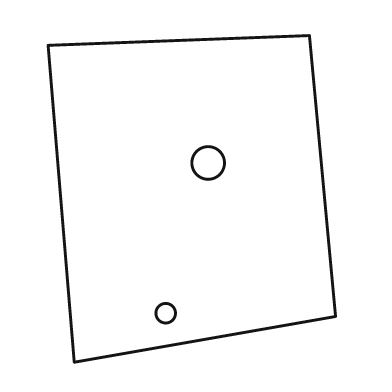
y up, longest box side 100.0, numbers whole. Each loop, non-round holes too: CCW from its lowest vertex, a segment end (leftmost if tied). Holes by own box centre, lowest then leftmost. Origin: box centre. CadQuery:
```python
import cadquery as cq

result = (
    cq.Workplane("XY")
    .moveTo(-36.0, -50.0)
    .lineTo(44.0, -36.0)
    .lineTo(36.0, 50.0)
    .lineTo(-44.0, 47.0)
    .close()
    .moveTo(-8.0, -35.0)
    .circle(3.0)
    .moveTo(5.0, 11.0)
    .circle(5.0)
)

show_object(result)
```